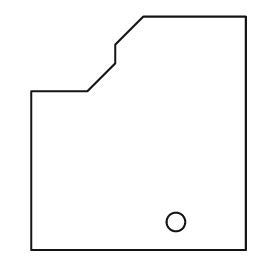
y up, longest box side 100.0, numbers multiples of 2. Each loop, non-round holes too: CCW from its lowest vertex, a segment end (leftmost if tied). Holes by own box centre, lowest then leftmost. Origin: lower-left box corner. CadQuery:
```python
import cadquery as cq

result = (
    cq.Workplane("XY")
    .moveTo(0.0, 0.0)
    .lineTo(92.0, 0.0)
    .lineTo(92.0, 100.0)
    .lineTo(48.0, 100.0)
    .lineTo(36.0, 88.0)
    .lineTo(36.0, 80.0)
    .lineTo(24.0, 68.0)
    .lineTo(0.0, 68.0)
    .close()
    .moveTo(62.0, 12.0)
    .circle(4.0)
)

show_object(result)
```